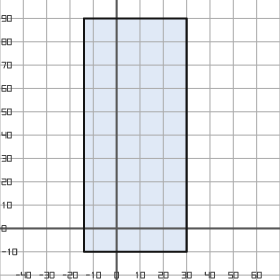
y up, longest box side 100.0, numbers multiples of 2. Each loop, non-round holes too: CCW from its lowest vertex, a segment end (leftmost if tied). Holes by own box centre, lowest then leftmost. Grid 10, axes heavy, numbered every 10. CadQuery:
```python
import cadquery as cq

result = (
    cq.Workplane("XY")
    .moveTo(-14.0, -10.0)
    .lineTo(30.0, -10.0)
    .lineTo(30.0, 90.0)
    .lineTo(-14.0, 90.0)
    .close()
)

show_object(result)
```